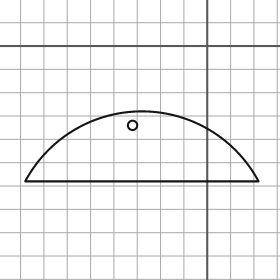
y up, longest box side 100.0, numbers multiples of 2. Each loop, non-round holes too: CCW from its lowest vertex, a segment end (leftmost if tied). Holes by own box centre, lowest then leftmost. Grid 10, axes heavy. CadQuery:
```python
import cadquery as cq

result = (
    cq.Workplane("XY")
    .moveTo(-78.0, -58.0)
    .lineTo(22.0, -58.0)
    .threePointArc((-28.0, -28.0), (-78.0, -58.0))
    .close()
    .moveTo(-32.0, -34.0)
    .circle(2.0)
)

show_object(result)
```